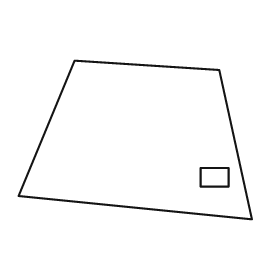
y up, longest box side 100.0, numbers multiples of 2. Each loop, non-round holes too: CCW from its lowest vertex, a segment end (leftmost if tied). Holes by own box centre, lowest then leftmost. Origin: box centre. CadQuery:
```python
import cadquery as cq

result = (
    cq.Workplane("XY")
    .moveTo(50.0, -34.0)
    .lineTo(36.0, 30.0)
    .lineTo(-26.0, 34.0)
    .lineTo(-50.0, -24.0)
    .close()
    .moveTo(28.0, -20.0)
    .lineTo(40.0, -20.0)
    .lineTo(40.0, -12.0)
    .lineTo(28.0, -12.0)
    .close()
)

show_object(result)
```